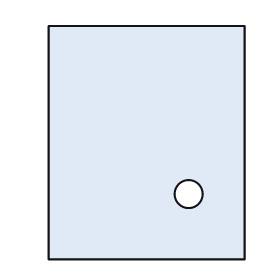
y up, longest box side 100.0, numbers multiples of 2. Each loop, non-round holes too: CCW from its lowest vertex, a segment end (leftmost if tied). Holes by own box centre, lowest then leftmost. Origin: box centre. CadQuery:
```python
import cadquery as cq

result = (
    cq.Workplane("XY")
    .moveTo(-42.0, -50.0)
    .lineTo(42.0, -50.0)
    .lineTo(42.0, 50.0)
    .lineTo(-42.0, 50.0)
    .close()
    .moveTo(18.0, -22.0)
    .circle(6.0)
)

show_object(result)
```